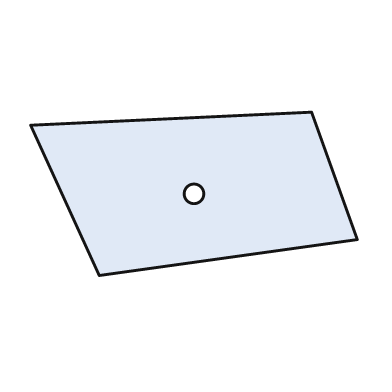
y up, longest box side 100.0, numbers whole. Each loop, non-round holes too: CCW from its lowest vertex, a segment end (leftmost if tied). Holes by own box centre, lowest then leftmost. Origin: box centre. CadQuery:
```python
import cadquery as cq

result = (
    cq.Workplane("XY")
    .moveTo(-29.0, -25.0)
    .lineTo(50.0, -14.0)
    .lineTo(36.0, 25.0)
    .lineTo(-50.0, 21.0)
    .close()
    .moveTo(0.0, 0.0)
    .circle(3.0)
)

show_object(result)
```